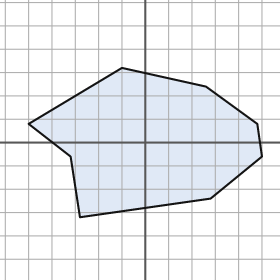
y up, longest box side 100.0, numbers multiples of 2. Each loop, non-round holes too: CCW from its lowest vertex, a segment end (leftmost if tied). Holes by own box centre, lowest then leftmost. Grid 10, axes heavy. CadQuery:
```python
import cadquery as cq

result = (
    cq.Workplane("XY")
    .moveTo(-28.0, -32.0)
    .lineTo(28.0, -24.0)
    .lineTo(50.0, -6.0)
    .lineTo(48.0, 8.0)
    .lineTo(26.0, 24.0)
    .lineTo(-10.0, 32.0)
    .lineTo(-50.0, 8.0)
    .lineTo(-32.0, -6.0)
    .close()
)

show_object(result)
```